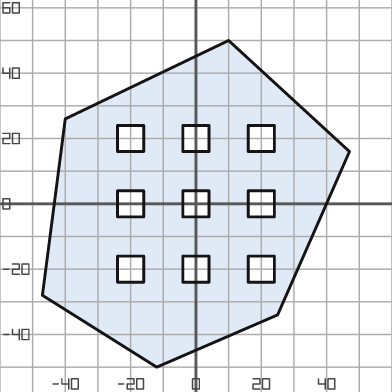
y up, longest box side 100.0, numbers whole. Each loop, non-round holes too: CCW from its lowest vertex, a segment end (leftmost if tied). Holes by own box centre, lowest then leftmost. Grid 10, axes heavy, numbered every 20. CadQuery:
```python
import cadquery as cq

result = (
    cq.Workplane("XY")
    .moveTo(-12.0, -50.0)
    .lineTo(25.0, -34.0)
    .lineTo(47.0, 16.0)
    .lineTo(10.0, 50.0)
    .lineTo(-40.0, 26.0)
    .lineTo(-47.0, -28.0)
    .close()
    .moveTo(-24.0, -24.0)
    .lineTo(-16.0, -24.0)
    .lineTo(-16.0, -16.0)
    .lineTo(-24.0, -16.0)
    .close()
    .moveTo(-4.0, -24.0)
    .lineTo(4.0, -24.0)
    .lineTo(4.0, -16.0)
    .lineTo(-4.0, -16.0)
    .close()
    .moveTo(16.0, -24.0)
    .lineTo(24.0, -24.0)
    .lineTo(24.0, -16.0)
    .lineTo(16.0, -16.0)
    .close()
    .moveTo(-24.0, -4.0)
    .lineTo(-16.0, -4.0)
    .lineTo(-16.0, 4.0)
    .lineTo(-24.0, 4.0)
    .close()
    .moveTo(-4.0, -4.0)
    .lineTo(4.0, -4.0)
    .lineTo(4.0, 4.0)
    .lineTo(-4.0, 4.0)
    .close()
    .moveTo(16.0, -4.0)
    .lineTo(24.0, -4.0)
    .lineTo(24.0, 4.0)
    .lineTo(16.0, 4.0)
    .close()
    .moveTo(-24.0, 16.0)
    .lineTo(-16.0, 16.0)
    .lineTo(-16.0, 24.0)
    .lineTo(-24.0, 24.0)
    .close()
    .moveTo(-4.0, 16.0)
    .lineTo(4.0, 16.0)
    .lineTo(4.0, 24.0)
    .lineTo(-4.0, 24.0)
    .close()
    .moveTo(16.0, 16.0)
    .lineTo(24.0, 16.0)
    .lineTo(24.0, 24.0)
    .lineTo(16.0, 24.0)
    .close()
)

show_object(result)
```